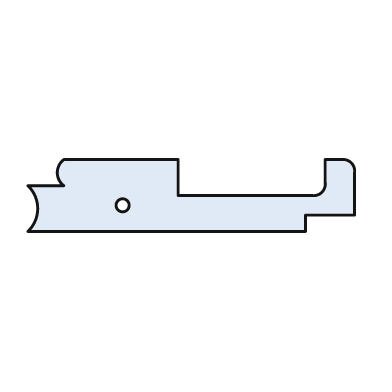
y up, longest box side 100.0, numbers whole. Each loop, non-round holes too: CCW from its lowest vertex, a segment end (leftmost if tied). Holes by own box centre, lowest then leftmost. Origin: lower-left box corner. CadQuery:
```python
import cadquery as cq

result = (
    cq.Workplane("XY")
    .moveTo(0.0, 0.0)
    .lineTo(85.0, 0.0)
    .lineTo(85.0, 5.0)
    .lineTo(100.0, 5.0)
    .lineTo(100.0, 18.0)
    .threePointArc((99.0, 21.0), (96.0, 22.0))
    .lineTo(91.0, 22.0)
    .lineTo(91.0, 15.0)
    .threePointArc((90.0, 12.0), (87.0, 11.0))
    .lineTo(46.0, 11.0)
    .lineTo(46.0, 22.0)
    .lineTo(11.0, 22.0)
    .threePointArc((9.0, 18.0), (11.0, 14.0))
    .lineTo(0.0, 14.0)
    .threePointArc((3.0, 7.0), (0.0, 0.0))
    .close()
    .moveTo(29.0, 8.0)
    .circle(2.0)
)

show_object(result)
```